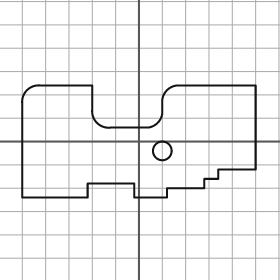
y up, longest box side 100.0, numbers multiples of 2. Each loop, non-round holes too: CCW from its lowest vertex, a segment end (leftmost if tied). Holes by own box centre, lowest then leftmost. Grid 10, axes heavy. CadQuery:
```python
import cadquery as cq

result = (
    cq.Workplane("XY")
    .moveTo(-50.0, -24.0)
    .lineTo(-22.0, -24.0)
    .lineTo(-22.0, -18.0)
    .lineTo(-2.0, -18.0)
    .lineTo(-2.0, -24.0)
    .lineTo(12.0, -24.0)
    .lineTo(12.0, -20.0)
    .lineTo(28.0, -20.0)
    .lineTo(28.0, -16.0)
    .lineTo(34.0, -16.0)
    .lineTo(34.0, -12.0)
    .lineTo(50.0, -12.0)
    .lineTo(50.0, 24.0)
    .lineTo(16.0, 24.0)
    .threePointArc((12.0, 22.0), (10.0, 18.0))
    .lineTo(10.0, 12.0)
    .threePointArc((8.0, 8.0), (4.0, 6.0))
    .lineTo(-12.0, 6.0)
    .threePointArc((-18.0, 8.0), (-20.0, 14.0))
    .lineTo(-20.0, 24.0)
    .lineTo(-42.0, 24.0)
    .threePointArc((-48.0, 22.0), (-50.0, 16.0))
    .close()
    .moveTo(10.0, -4.0)
    .circle(4.0)
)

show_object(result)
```